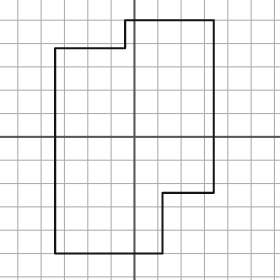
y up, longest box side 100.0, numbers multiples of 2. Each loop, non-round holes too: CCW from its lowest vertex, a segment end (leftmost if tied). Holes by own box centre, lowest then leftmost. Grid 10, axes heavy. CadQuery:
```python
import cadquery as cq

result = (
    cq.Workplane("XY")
    .moveTo(-34.0, -50.0)
    .lineTo(12.0, -50.0)
    .lineTo(12.0, -24.0)
    .lineTo(34.0, -24.0)
    .lineTo(34.0, 50.0)
    .lineTo(-4.0, 50.0)
    .lineTo(-4.0, 38.0)
    .lineTo(-34.0, 38.0)
    .close()
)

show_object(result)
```